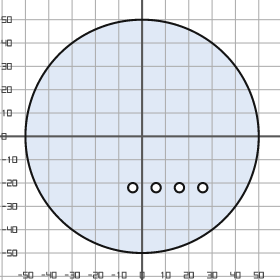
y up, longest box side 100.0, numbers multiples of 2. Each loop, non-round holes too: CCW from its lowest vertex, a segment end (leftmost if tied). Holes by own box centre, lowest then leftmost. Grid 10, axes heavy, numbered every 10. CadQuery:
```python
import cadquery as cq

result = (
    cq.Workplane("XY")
    .moveTo(0.0, 0.0)
    .circle(50.0)
    .moveTo(-4.0, -22.0)
    .circle(2.0)
    .moveTo(6.0, -22.0)
    .circle(2.0)
    .moveTo(16.0, -22.0)
    .circle(2.0)
    .moveTo(26.0, -22.0)
    .circle(2.0)
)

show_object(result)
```